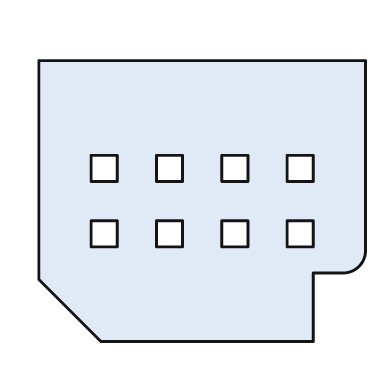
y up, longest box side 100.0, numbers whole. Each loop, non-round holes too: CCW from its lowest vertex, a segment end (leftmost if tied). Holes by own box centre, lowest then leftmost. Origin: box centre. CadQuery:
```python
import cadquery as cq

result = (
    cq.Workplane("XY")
    .moveTo(-31.0, -43.0)
    .lineTo(34.0, -43.0)
    .lineTo(34.0, -22.0)
    .lineTo(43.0, -22.0)
    .threePointArc((48.0, -20.0), (50.0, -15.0))
    .lineTo(50.0, 43.0)
    .lineTo(-50.0, 43.0)
    .lineTo(-50.0, -24.0)
    .close()
    .moveTo(-34.0, -14.0)
    .lineTo(-26.0, -14.0)
    .lineTo(-26.0, -6.0)
    .lineTo(-34.0, -6.0)
    .close()
    .moveTo(-14.0, -14.0)
    .lineTo(-6.0, -14.0)
    .lineTo(-6.0, -6.0)
    .lineTo(-14.0, -6.0)
    .close()
    .moveTo(6.0, -14.0)
    .lineTo(14.0, -14.0)
    .lineTo(14.0, -6.0)
    .lineTo(6.0, -6.0)
    .close()
    .moveTo(26.0, -14.0)
    .lineTo(34.0, -14.0)
    .lineTo(34.0, -6.0)
    .lineTo(26.0, -6.0)
    .close()
    .moveTo(-34.0, 6.0)
    .lineTo(-26.0, 6.0)
    .lineTo(-26.0, 14.0)
    .lineTo(-34.0, 14.0)
    .close()
    .moveTo(-14.0, 6.0)
    .lineTo(-6.0, 6.0)
    .lineTo(-6.0, 14.0)
    .lineTo(-14.0, 14.0)
    .close()
    .moveTo(6.0, 6.0)
    .lineTo(14.0, 6.0)
    .lineTo(14.0, 14.0)
    .lineTo(6.0, 14.0)
    .close()
    .moveTo(26.0, 6.0)
    .lineTo(34.0, 6.0)
    .lineTo(34.0, 14.0)
    .lineTo(26.0, 14.0)
    .close()
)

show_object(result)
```